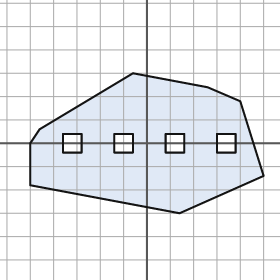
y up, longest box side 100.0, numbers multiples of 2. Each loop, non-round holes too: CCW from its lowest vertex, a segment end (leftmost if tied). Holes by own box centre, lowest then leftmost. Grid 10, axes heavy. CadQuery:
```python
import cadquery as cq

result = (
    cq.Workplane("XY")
    .moveTo(14.0, -30.0)
    .lineTo(50.0, -14.0)
    .lineTo(40.0, 18.0)
    .lineTo(26.0, 24.0)
    .lineTo(-6.0, 30.0)
    .lineTo(-46.0, 6.0)
    .lineTo(-50.0, 0.0)
    .lineTo(-50.0, -18.0)
    .close()
    .moveTo(-36.0, -4.0)
    .lineTo(-28.0, -4.0)
    .lineTo(-28.0, 4.0)
    .lineTo(-36.0, 4.0)
    .close()
    .moveTo(-14.0, -4.0)
    .lineTo(-6.0, -4.0)
    .lineTo(-6.0, 4.0)
    .lineTo(-14.0, 4.0)
    .close()
    .moveTo(8.0, -4.0)
    .lineTo(16.0, -4.0)
    .lineTo(16.0, 4.0)
    .lineTo(8.0, 4.0)
    .close()
    .moveTo(30.0, -4.0)
    .lineTo(38.0, -4.0)
    .lineTo(38.0, 4.0)
    .lineTo(30.0, 4.0)
    .close()
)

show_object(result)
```